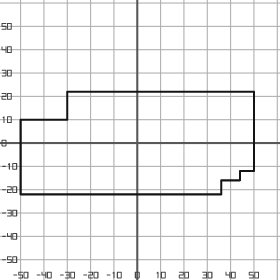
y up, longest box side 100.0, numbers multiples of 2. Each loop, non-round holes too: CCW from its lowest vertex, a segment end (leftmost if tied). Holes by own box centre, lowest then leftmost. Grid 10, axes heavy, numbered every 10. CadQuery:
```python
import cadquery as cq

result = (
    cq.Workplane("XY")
    .moveTo(-50.0, -22.0)
    .lineTo(36.0, -22.0)
    .lineTo(36.0, -16.0)
    .lineTo(44.0, -16.0)
    .lineTo(44.0, -12.0)
    .lineTo(50.0, -12.0)
    .lineTo(50.0, 22.0)
    .lineTo(-30.0, 22.0)
    .lineTo(-30.0, 10.0)
    .lineTo(-50.0, 10.0)
    .close()
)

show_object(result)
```